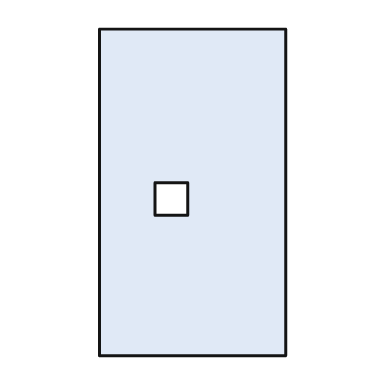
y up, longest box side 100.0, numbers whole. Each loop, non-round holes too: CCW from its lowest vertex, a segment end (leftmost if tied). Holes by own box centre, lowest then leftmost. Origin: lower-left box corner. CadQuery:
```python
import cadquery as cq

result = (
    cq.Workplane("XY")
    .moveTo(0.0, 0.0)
    .lineTo(57.0, 0.0)
    .lineTo(57.0, 100.0)
    .lineTo(0.0, 100.0)
    .close()
    .moveTo(17.0, 43.0)
    .lineTo(27.0, 43.0)
    .lineTo(27.0, 53.0)
    .lineTo(17.0, 53.0)
    .close()
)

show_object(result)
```